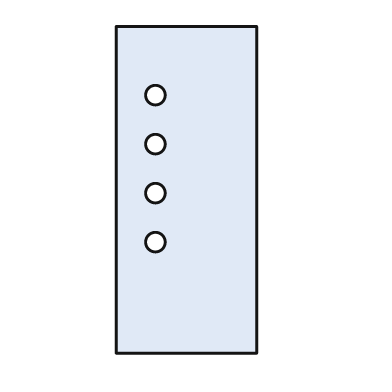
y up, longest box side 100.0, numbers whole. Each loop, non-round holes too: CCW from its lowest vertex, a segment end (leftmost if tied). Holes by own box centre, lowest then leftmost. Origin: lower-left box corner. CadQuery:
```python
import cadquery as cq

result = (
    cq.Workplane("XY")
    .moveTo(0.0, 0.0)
    .lineTo(43.0, 0.0)
    .lineTo(43.0, 100.0)
    .lineTo(0.0, 100.0)
    .close()
    .moveTo(12.0, 34.0)
    .circle(3.0)
    .moveTo(12.0, 49.0)
    .circle(3.0)
    .moveTo(12.0, 64.0)
    .circle(3.0)
    .moveTo(12.0, 79.0)
    .circle(3.0)
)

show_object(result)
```